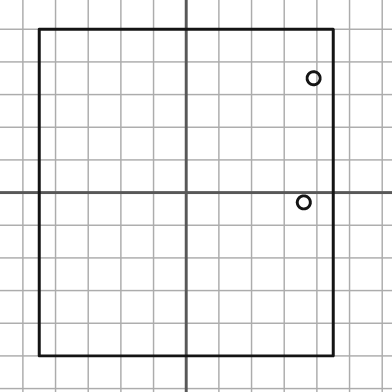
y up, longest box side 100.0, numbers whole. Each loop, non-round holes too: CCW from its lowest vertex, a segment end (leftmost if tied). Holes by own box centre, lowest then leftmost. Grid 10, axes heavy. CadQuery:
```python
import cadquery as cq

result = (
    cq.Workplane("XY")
    .moveTo(-45.0, -50.0)
    .lineTo(45.0, -50.0)
    .lineTo(45.0, 50.0)
    .lineTo(-45.0, 50.0)
    .close()
    .moveTo(36.0, -3.0)
    .circle(2.0)
    .moveTo(39.0, 35.0)
    .circle(2.0)
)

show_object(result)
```